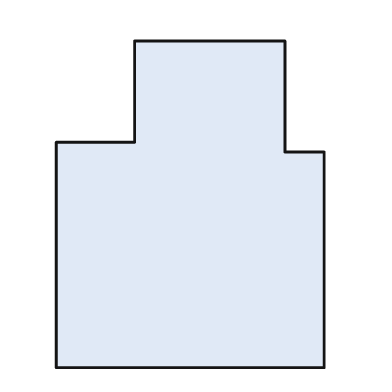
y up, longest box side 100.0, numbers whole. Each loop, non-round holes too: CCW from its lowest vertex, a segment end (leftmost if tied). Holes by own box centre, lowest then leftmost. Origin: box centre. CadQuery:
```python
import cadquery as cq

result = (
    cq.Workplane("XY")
    .moveTo(-41.0, -50.0)
    .lineTo(41.0, -50.0)
    .lineTo(41.0, 16.0)
    .lineTo(29.0, 16.0)
    .lineTo(29.0, 50.0)
    .lineTo(-17.0, 50.0)
    .lineTo(-17.0, 19.0)
    .lineTo(-41.0, 19.0)
    .close()
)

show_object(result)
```